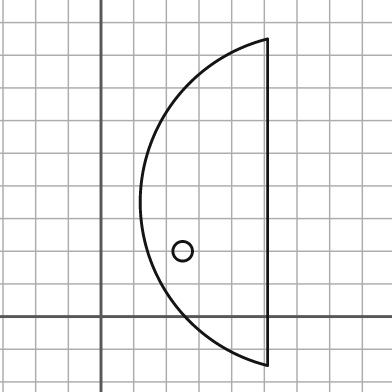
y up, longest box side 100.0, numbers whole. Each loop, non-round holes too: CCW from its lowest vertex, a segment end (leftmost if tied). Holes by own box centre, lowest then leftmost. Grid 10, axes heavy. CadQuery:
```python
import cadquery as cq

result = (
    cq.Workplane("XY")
    .moveTo(51.0, -15.0)
    .lineTo(51.0, 85.0)
    .threePointArc((12.0, 35.0), (51.0, -15.0))
    .close()
    .moveTo(25.0, 20.0)
    .circle(3.0)
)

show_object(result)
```